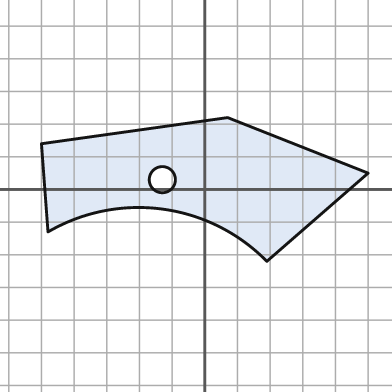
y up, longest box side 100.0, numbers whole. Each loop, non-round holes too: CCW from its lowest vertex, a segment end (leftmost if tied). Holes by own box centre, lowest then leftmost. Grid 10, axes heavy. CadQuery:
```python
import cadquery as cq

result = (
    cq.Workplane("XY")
    .moveTo(19.0, -22.0)
    .lineTo(50.0, 5.0)
    .lineTo(7.0, 22.0)
    .lineTo(-50.0, 14.0)
    .lineTo(-48.0, -13.0)
    .threePointArc((-13.0, -6.0), (19.0, -22.0))
    .close()
    .moveTo(-13.0, 3.0)
    .circle(4.0)
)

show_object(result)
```